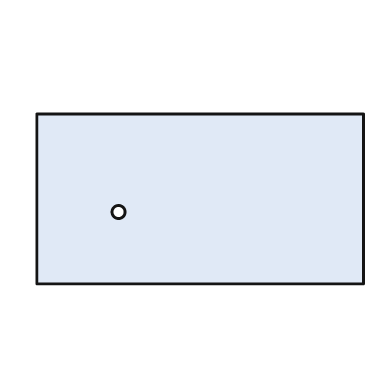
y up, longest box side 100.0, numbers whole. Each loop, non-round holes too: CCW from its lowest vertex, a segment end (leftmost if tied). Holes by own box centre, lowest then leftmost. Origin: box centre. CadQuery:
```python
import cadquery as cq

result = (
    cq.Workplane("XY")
    .moveTo(-50.0, -26.0)
    .lineTo(50.0, -26.0)
    .lineTo(50.0, 26.0)
    .lineTo(-50.0, 26.0)
    .close()
    .moveTo(-25.0, -4.0)
    .circle(2.0)
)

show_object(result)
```